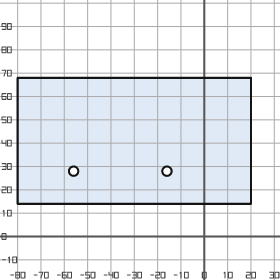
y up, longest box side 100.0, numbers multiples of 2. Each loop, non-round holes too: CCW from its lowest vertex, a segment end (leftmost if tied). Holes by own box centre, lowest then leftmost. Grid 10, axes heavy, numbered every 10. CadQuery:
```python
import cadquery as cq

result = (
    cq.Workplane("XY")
    .moveTo(-80.0, 14.0)
    .lineTo(20.0, 14.0)
    .lineTo(20.0, 68.0)
    .lineTo(-80.0, 68.0)
    .close()
    .moveTo(-56.0, 28.0)
    .circle(2.0)
    .moveTo(-16.0, 28.0)
    .circle(2.0)
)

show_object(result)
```